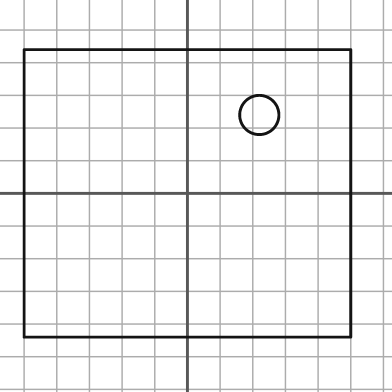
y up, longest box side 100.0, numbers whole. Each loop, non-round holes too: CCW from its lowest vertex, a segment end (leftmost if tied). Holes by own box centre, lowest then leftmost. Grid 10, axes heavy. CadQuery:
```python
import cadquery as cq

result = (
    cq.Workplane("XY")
    .moveTo(-50.0, -44.0)
    .lineTo(50.0, -44.0)
    .lineTo(50.0, 44.0)
    .lineTo(-50.0, 44.0)
    .close()
    .moveTo(22.0, 24.0)
    .circle(6.0)
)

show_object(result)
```